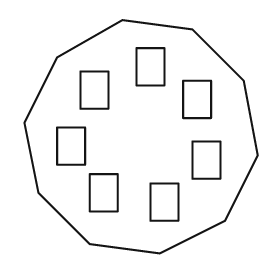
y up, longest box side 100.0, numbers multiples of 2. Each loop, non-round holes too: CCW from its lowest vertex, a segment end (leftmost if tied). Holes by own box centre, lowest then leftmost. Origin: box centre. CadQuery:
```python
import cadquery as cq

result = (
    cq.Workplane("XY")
    .moveTo(8.0, -50.0)
    .lineTo(36.0, -36.0)
    .lineTo(50.0, -8.0)
    .lineTo(44.0, 24.0)
    .lineTo(22.0, 46.0)
    .lineTo(-8.0, 50.0)
    .lineTo(-36.0, 34.0)
    .lineTo(-50.0, 6.0)
    .lineTo(-44.0, -24.0)
    .lineTo(-22.0, -46.0)
    .close()
    .moveTo(4.0, -36.0)
    .lineTo(16.0, -36.0)
    .lineTo(16.0, -20.0)
    .lineTo(4.0, -20.0)
    .close()
    .moveTo(-22.0, -32.0)
    .lineTo(-10.0, -32.0)
    .lineTo(-10.0, -16.0)
    .lineTo(-22.0, -16.0)
    .close()
    .moveTo(22.0, -18.0)
    .lineTo(34.0, -18.0)
    .lineTo(34.0, -2.0)
    .lineTo(22.0, -2.0)
    .close()
    .moveTo(-36.0, -12.0)
    .lineTo(-24.0, -12.0)
    .lineTo(-24.0, 4.0)
    .lineTo(-36.0, 4.0)
    .close()
    .moveTo(18.0, 8.0)
    .lineTo(30.0, 8.0)
    .lineTo(30.0, 24.0)
    .lineTo(18.0, 24.0)
    .close()
    .moveTo(-26.0, 12.0)
    .lineTo(-14.0, 12.0)
    .lineTo(-14.0, 28.0)
    .lineTo(-26.0, 28.0)
    .close()
    .moveTo(-2.0, 22.0)
    .lineTo(10.0, 22.0)
    .lineTo(10.0, 38.0)
    .lineTo(-2.0, 38.0)
    .close()
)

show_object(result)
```